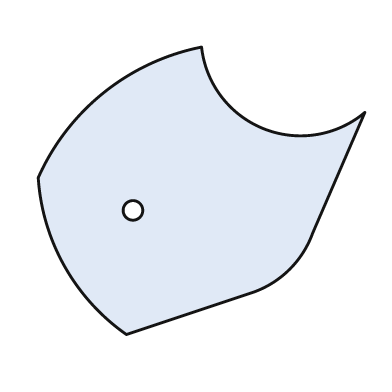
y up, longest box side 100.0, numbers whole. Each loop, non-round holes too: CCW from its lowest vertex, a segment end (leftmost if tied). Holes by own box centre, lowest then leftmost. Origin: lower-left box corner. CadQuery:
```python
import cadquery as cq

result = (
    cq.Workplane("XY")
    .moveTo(27.0, 0.0)
    .lineTo(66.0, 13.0)
    .threePointArc((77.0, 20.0), (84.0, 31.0))
    .lineTo(100.0, 68.0)
    .threePointArc((69.0, 63.0), (50.0, 88.0))
    .threePointArc((20.0, 74.0), (0.0, 48.0))
    .threePointArc((8.0, 21.0), (27.0, 0.0))
    .close()
    .moveTo(29.0, 38.0)
    .circle(3.0)
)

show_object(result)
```